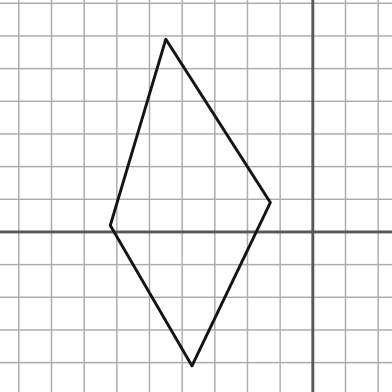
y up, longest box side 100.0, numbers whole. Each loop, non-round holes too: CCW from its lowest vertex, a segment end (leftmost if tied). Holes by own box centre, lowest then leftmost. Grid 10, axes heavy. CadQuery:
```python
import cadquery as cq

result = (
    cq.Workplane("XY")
    .moveTo(-37.0, -41.0)
    .lineTo(-13.0, 9.0)
    .lineTo(-45.0, 59.0)
    .lineTo(-62.0, 2.0)
    .close()
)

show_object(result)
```